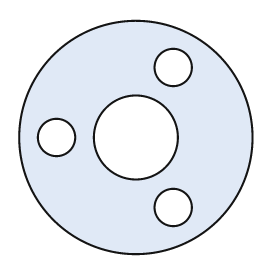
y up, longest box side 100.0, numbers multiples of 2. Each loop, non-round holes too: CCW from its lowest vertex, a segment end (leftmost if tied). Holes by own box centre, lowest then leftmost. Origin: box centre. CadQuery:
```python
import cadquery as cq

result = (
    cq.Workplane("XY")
    .moveTo(0.0, 0.0)
    .circle(50.0)
    .moveTo(16.0, -30.0)
    .circle(8.0)
    .moveTo(-34.0, 0.0)
    .circle(8.0)
    .moveTo(0.0, 0.0)
    .circle(18.0)
    .moveTo(16.0, 30.0)
    .circle(8.0)
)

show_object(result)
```